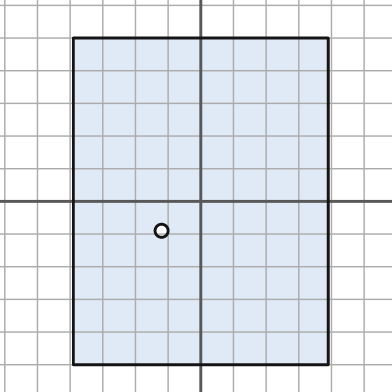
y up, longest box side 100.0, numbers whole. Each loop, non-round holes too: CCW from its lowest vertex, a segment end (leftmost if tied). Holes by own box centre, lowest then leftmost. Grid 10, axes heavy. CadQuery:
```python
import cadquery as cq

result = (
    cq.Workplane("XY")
    .moveTo(-39.0, -50.0)
    .lineTo(39.0, -50.0)
    .lineTo(39.0, 50.0)
    .lineTo(-39.0, 50.0)
    .close()
    .moveTo(-12.0, -9.0)
    .circle(2.0)
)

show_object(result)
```